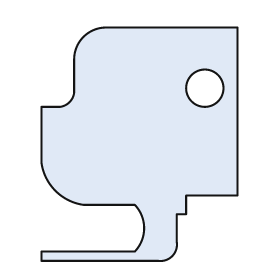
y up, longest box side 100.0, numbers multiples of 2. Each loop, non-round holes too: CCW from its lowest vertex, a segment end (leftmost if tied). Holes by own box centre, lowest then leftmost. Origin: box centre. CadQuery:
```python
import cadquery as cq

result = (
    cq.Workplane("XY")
    .moveTo(-42.0, -50.0)
    .lineTo(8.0, -50.0)
    .threePointArc((14.0, -48.0), (16.0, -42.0))
    .lineTo(16.0, -30.0)
    .lineTo(20.0, -30.0)
    .lineTo(20.0, -22.0)
    .lineTo(42.0, -22.0)
    .lineTo(42.0, 50.0)
    .lineTo(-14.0, 50.0)
    .threePointArc((-24.0, 46.0), (-28.0, 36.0))
    .lineTo(-28.0, 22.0)
    .threePointArc((-30.0, 18.0), (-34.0, 16.0))
    .lineTo(-42.0, 16.0)
    .lineTo(-42.0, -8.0)
    .threePointArc((-36.0, -20.0), (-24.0, -26.0))
    .lineTo(-2.0, -26.0)
    .threePointArc((2.0, -36.0), (-2.0, -46.0))
    .lineTo(-42.0, -46.0)
    .close()
    .moveTo(28.0, 24.0)
    .circle(8.0)
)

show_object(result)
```